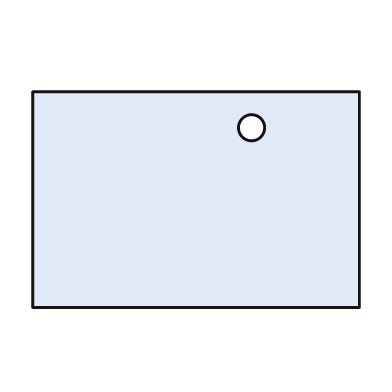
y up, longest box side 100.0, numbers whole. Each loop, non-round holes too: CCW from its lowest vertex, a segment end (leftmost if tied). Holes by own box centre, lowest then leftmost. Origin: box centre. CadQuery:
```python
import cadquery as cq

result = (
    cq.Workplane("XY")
    .moveTo(-50.0, -33.0)
    .lineTo(50.0, -33.0)
    .lineTo(50.0, 33.0)
    .lineTo(-50.0, 33.0)
    .close()
    .moveTo(17.0, 22.0)
    .circle(4.0)
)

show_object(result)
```